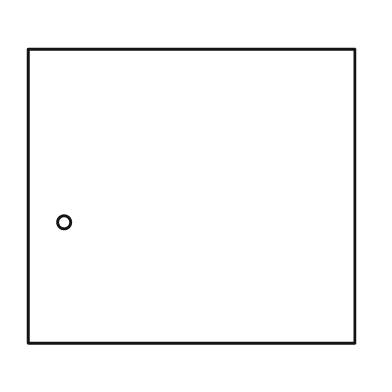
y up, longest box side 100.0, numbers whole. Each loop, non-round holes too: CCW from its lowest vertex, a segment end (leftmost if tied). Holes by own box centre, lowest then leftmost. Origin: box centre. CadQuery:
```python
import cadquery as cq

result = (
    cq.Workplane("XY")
    .moveTo(-50.0, -45.0)
    .lineTo(50.0, -45.0)
    .lineTo(50.0, 45.0)
    .lineTo(-50.0, 45.0)
    .close()
    .moveTo(-39.0, -8.0)
    .circle(2.0)
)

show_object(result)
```